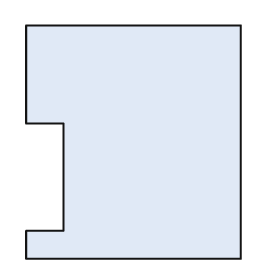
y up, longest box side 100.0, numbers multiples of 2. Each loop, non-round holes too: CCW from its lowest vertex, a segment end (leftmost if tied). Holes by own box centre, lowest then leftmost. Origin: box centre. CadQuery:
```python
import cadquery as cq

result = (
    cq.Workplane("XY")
    .moveTo(-46.0, -50.0)
    .lineTo(46.0, -50.0)
    .lineTo(46.0, 50.0)
    .lineTo(-46.0, 50.0)
    .lineTo(-46.0, 8.0)
    .lineTo(-30.0, 8.0)
    .lineTo(-30.0, -38.0)
    .lineTo(-46.0, -38.0)
    .close()
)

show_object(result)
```